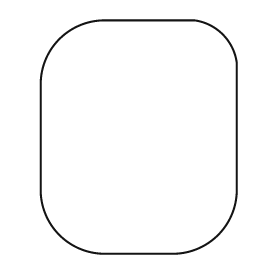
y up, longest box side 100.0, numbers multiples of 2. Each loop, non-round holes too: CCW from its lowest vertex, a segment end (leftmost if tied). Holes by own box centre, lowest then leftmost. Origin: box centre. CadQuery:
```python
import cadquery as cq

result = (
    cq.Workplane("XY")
    .moveTo(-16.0, -50.0)
    .lineTo(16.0, -50.0)
    .threePointArc((34.0, -42.0), (42.0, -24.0))
    .lineTo(42.0, 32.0)
    .threePointArc((36.0, 44.0), (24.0, 50.0))
    .lineTo(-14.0, 50.0)
    .threePointArc((-34.0, 42.0), (-42.0, 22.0))
    .lineTo(-42.0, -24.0)
    .threePointArc((-34.0, -42.0), (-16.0, -50.0))
    .close()
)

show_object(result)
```